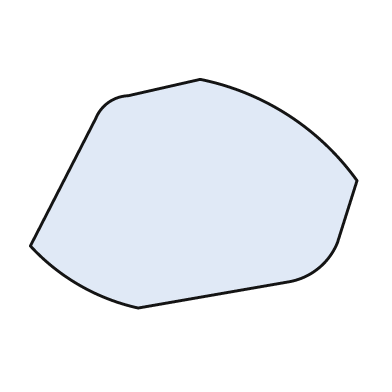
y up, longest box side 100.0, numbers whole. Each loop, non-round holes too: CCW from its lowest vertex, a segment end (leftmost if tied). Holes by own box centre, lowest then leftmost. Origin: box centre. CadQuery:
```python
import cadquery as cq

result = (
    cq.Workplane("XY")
    .moveTo(-17.0, -35.0)
    .lineTo(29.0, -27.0)
    .threePointArc((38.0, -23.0), (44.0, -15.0))
    .lineTo(50.0, 4.0)
    .threePointArc((29.0, 24.0), (2.0, 35.0))
    .lineTo(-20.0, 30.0)
    .threePointArc((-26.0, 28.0), (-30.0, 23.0))
    .lineTo(-50.0, -16.0)
    .threePointArc((-35.0, -28.0), (-17.0, -35.0))
    .close()
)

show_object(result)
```